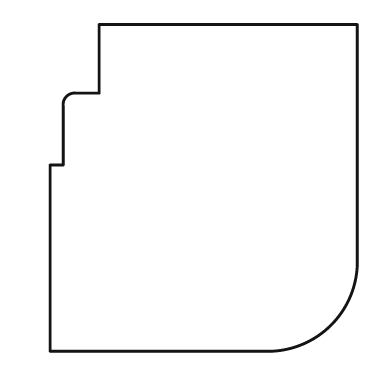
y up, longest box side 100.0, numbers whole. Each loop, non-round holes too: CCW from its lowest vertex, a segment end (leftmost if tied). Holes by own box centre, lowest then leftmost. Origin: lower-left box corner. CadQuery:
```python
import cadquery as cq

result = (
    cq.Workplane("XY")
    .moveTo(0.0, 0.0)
    .lineTo(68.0, 0.0)
    .threePointArc((86.0, 8.0), (94.0, 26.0))
    .lineTo(94.0, 100.0)
    .lineTo(15.0, 100.0)
    .lineTo(15.0, 79.0)
    .lineTo(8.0, 79.0)
    .threePointArc((5.0, 78.0), (4.0, 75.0))
    .lineTo(4.0, 57.0)
    .lineTo(0.0, 57.0)
    .close()
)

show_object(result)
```